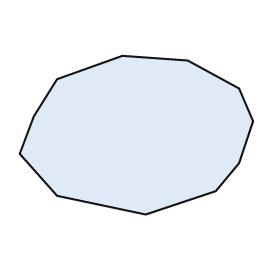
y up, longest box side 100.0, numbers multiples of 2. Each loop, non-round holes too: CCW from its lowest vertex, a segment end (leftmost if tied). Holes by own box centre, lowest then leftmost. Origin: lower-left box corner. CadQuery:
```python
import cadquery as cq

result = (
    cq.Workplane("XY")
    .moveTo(54.0, 0.0)
    .lineTo(84.0, 10.0)
    .lineTo(94.0, 22.0)
    .lineTo(100.0, 40.0)
    .lineTo(94.0, 54.0)
    .lineTo(72.0, 66.0)
    .lineTo(44.0, 68.0)
    .lineTo(16.0, 58.0)
    .lineTo(6.0, 42.0)
    .lineTo(0.0, 26.0)
    .lineTo(16.0, 8.0)
    .close()
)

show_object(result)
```